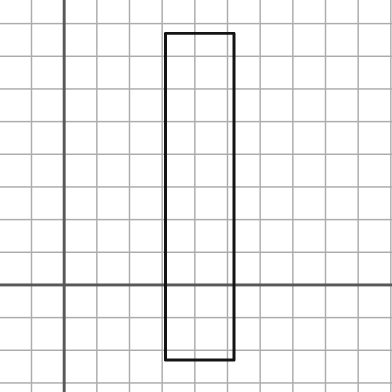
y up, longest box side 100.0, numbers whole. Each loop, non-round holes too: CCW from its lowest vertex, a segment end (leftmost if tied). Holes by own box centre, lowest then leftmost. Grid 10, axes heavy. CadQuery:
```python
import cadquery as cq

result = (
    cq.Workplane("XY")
    .moveTo(31.0, -23.0)
    .lineTo(52.0, -23.0)
    .lineTo(52.0, 77.0)
    .lineTo(31.0, 77.0)
    .close()
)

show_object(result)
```